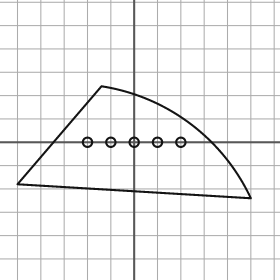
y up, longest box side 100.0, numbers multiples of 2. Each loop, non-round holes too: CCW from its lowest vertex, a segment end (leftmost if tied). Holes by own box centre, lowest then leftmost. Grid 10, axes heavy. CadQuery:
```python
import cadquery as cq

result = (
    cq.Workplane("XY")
    .moveTo(50.0, -24.0)
    .threePointArc((24.0, 8.0), (-14.0, 24.0))
    .lineTo(-50.0, -18.0)
    .close()
    .moveTo(-20.0, 0.0)
    .circle(2.0)
    .moveTo(-10.0, 0.0)
    .circle(2.0)
    .moveTo(0.0, 0.0)
    .circle(2.0)
    .moveTo(10.0, 0.0)
    .circle(2.0)
    .moveTo(20.0, 0.0)
    .circle(2.0)
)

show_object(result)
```